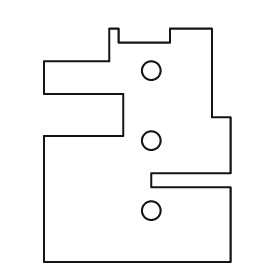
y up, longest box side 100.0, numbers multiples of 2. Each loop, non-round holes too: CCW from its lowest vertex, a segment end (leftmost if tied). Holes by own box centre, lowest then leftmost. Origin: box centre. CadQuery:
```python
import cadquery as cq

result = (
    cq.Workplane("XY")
    .moveTo(-40.0, -50.0)
    .lineTo(40.0, -50.0)
    .lineTo(40.0, -18.0)
    .lineTo(6.0, -18.0)
    .lineTo(6.0, -12.0)
    .lineTo(40.0, -12.0)
    .lineTo(40.0, 12.0)
    .lineTo(32.0, 12.0)
    .lineTo(32.0, 50.0)
    .lineTo(14.0, 50.0)
    .lineTo(14.0, 44.0)
    .lineTo(-8.0, 44.0)
    .lineTo(-8.0, 50.0)
    .lineTo(-12.0, 50.0)
    .lineTo(-12.0, 36.0)
    .lineTo(-40.0, 36.0)
    .lineTo(-40.0, 22.0)
    .lineTo(-6.0, 22.0)
    .lineTo(-6.0, 4.0)
    .lineTo(-40.0, 4.0)
    .close()
    .moveTo(6.0, -28.0)
    .circle(4.0)
    .moveTo(6.0, 2.0)
    .circle(4.0)
    .moveTo(6.0, 32.0)
    .circle(4.0)
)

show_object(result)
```